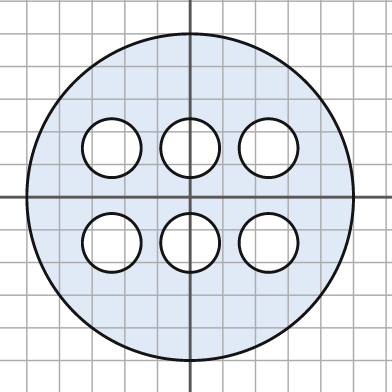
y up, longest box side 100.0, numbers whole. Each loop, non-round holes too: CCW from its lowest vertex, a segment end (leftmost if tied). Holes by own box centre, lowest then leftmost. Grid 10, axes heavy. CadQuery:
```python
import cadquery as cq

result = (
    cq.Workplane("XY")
    .moveTo(0.0, 0.0)
    .circle(50.0)
    .moveTo(-24.0, -14.0)
    .circle(9.0)
    .moveTo(0.0, -14.0)
    .circle(9.0)
    .moveTo(24.0, -14.0)
    .circle(9.0)
    .moveTo(-24.0, 15.0)
    .circle(9.0)
    .moveTo(0.0, 15.0)
    .circle(9.0)
    .moveTo(24.0, 15.0)
    .circle(9.0)
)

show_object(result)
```